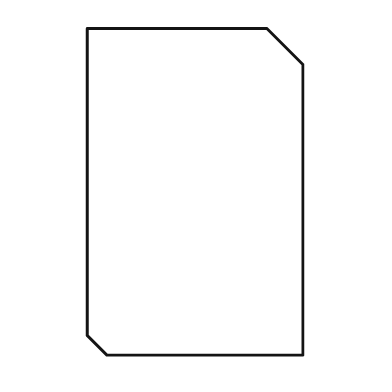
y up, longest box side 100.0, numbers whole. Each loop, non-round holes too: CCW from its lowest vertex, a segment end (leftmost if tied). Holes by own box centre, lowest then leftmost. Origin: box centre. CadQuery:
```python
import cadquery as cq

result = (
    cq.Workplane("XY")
    .moveTo(-27.0, -50.0)
    .lineTo(33.0, -50.0)
    .lineTo(33.0, 39.0)
    .lineTo(22.0, 50.0)
    .lineTo(-33.0, 50.0)
    .lineTo(-33.0, -44.0)
    .close()
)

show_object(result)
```